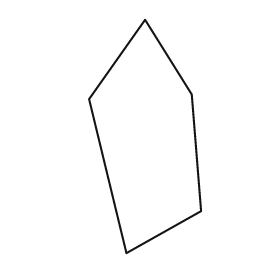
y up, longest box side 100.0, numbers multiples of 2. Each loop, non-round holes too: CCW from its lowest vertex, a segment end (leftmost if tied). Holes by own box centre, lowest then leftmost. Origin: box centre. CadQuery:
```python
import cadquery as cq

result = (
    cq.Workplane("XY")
    .moveTo(-8.0, -50.0)
    .lineTo(24.0, -32.0)
    .lineTo(20.0, 18.0)
    .lineTo(0.0, 50.0)
    .lineTo(-24.0, 16.0)
    .close()
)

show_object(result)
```